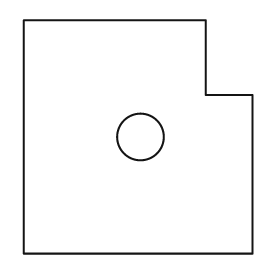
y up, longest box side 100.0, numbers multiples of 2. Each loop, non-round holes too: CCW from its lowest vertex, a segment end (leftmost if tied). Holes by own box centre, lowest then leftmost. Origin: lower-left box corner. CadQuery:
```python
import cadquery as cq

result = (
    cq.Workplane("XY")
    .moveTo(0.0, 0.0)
    .lineTo(98.0, 0.0)
    .lineTo(98.0, 68.0)
    .lineTo(78.0, 68.0)
    .lineTo(78.0, 100.0)
    .lineTo(0.0, 100.0)
    .close()
    .moveTo(50.0, 50.0)
    .circle(10.0)
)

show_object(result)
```